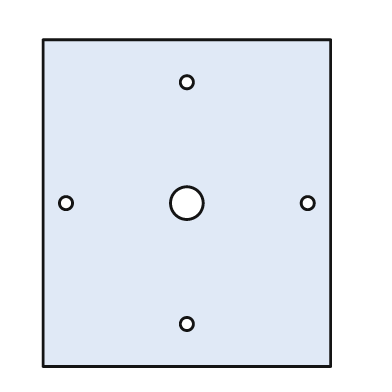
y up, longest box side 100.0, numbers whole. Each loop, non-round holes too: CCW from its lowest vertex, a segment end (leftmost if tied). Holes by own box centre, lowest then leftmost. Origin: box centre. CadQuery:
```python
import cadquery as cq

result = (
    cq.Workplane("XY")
    .moveTo(-44.0, -50.0)
    .lineTo(44.0, -50.0)
    .lineTo(44.0, 50.0)
    .lineTo(-44.0, 50.0)
    .close()
    .moveTo(0.0, -37.0)
    .circle(2.0)
    .moveTo(-37.0, 0.0)
    .circle(2.0)
    .moveTo(0.0, 0.0)
    .circle(5.0)
    .moveTo(37.0, 0.0)
    .circle(2.0)
    .moveTo(0.0, 37.0)
    .circle(2.0)
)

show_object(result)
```